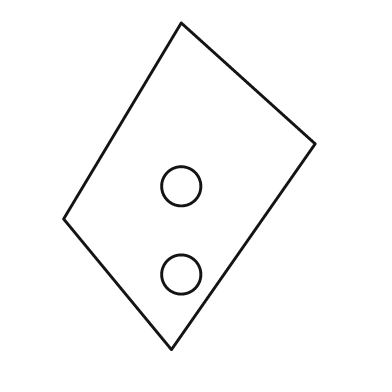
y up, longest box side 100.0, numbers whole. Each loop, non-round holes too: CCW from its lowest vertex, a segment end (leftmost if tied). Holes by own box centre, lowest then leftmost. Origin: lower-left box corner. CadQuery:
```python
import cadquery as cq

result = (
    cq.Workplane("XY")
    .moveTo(33.0, 0.0)
    .lineTo(77.0, 63.0)
    .lineTo(36.0, 100.0)
    .lineTo(0.0, 40.0)
    .close()
    .moveTo(36.0, 23.0)
    .circle(6.0)
    .moveTo(36.0, 50.0)
    .circle(6.0)
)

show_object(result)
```